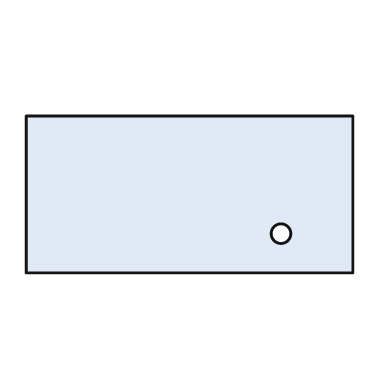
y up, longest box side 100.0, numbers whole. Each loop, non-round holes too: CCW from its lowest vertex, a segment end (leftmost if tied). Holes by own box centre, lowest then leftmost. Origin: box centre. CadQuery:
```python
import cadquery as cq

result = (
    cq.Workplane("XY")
    .moveTo(-50.0, -24.0)
    .lineTo(50.0, -24.0)
    .lineTo(50.0, 24.0)
    .lineTo(-50.0, 24.0)
    .close()
    .moveTo(28.0, -12.0)
    .circle(3.0)
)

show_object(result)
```